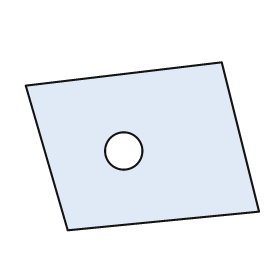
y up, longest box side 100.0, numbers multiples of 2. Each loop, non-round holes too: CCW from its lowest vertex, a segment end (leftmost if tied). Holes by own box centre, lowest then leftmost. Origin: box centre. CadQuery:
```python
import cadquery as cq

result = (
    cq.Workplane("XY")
    .moveTo(-32.0, -36.0)
    .lineTo(50.0, -28.0)
    .lineTo(34.0, 36.0)
    .lineTo(-50.0, 26.0)
    .close()
    .moveTo(-8.0, -2.0)
    .circle(8.0)
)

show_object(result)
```